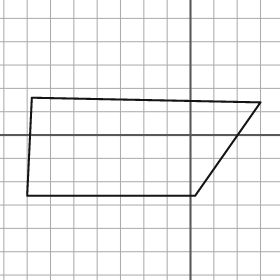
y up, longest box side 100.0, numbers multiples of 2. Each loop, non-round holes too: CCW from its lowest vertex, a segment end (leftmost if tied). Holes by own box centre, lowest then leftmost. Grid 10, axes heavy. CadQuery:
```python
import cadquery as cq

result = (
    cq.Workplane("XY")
    .moveTo(-70.0, -26.0)
    .lineTo(2.0, -26.0)
    .lineTo(30.0, 14.0)
    .lineTo(-68.0, 16.0)
    .close()
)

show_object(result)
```